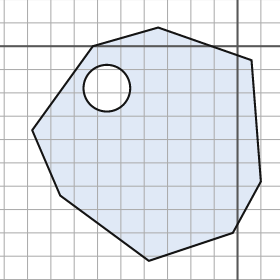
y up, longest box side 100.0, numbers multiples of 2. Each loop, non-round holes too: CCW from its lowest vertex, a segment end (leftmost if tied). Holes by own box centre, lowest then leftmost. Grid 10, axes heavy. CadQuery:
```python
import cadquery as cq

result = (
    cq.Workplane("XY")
    .moveTo(-38.0, -92.0)
    .lineTo(-2.0, -80.0)
    .lineTo(10.0, -58.0)
    .lineTo(6.0, -6.0)
    .lineTo(-34.0, 8.0)
    .lineTo(-62.0, 0.0)
    .lineTo(-88.0, -36.0)
    .lineTo(-76.0, -64.0)
    .close()
    .moveTo(-56.0, -18.0)
    .circle(10.0)
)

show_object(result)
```